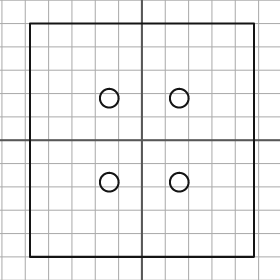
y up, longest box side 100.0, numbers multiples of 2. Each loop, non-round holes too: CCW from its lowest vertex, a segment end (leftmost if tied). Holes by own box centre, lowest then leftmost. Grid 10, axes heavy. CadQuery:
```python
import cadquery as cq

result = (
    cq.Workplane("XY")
    .moveTo(-48.0, -50.0)
    .lineTo(48.0, -50.0)
    .lineTo(48.0, 50.0)
    .lineTo(-48.0, 50.0)
    .close()
    .moveTo(-14.0, -18.0)
    .circle(4.0)
    .moveTo(16.0, -18.0)
    .circle(4.0)
    .moveTo(-14.0, 18.0)
    .circle(4.0)
    .moveTo(16.0, 18.0)
    .circle(4.0)
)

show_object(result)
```